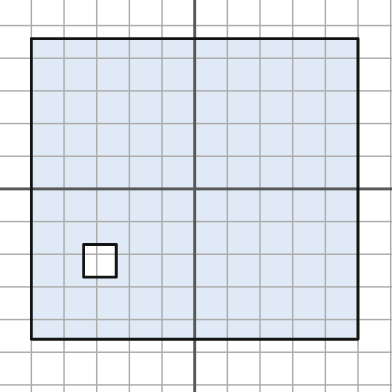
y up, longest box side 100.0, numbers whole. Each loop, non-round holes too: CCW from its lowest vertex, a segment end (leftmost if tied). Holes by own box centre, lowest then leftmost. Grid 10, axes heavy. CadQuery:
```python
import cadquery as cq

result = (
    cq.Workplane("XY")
    .moveTo(-50.0, -46.0)
    .lineTo(50.0, -46.0)
    .lineTo(50.0, 46.0)
    .lineTo(-50.0, 46.0)
    .close()
    .moveTo(-34.0, -27.0)
    .lineTo(-24.0, -27.0)
    .lineTo(-24.0, -17.0)
    .lineTo(-34.0, -17.0)
    .close()
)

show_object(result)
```